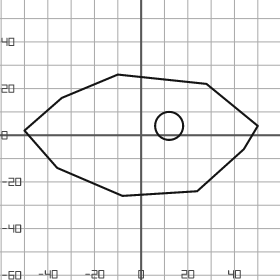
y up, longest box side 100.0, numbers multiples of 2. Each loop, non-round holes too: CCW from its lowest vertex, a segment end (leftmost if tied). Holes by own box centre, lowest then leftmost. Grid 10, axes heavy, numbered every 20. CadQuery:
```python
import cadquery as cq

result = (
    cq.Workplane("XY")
    .moveTo(-8.0, -26.0)
    .lineTo(24.0, -24.0)
    .lineTo(44.0, -6.0)
    .lineTo(50.0, 4.0)
    .lineTo(28.0, 22.0)
    .lineTo(-10.0, 26.0)
    .lineTo(-34.0, 16.0)
    .lineTo(-50.0, 2.0)
    .lineTo(-36.0, -14.0)
    .close()
    .moveTo(12.0, 4.0)
    .circle(6.0)
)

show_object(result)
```